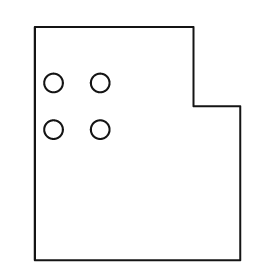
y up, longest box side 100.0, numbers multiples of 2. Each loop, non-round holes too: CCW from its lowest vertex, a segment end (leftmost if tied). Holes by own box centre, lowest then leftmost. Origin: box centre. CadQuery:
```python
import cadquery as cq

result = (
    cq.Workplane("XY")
    .moveTo(-44.0, -50.0)
    .lineTo(44.0, -50.0)
    .lineTo(44.0, 16.0)
    .lineTo(24.0, 16.0)
    .lineTo(24.0, 50.0)
    .lineTo(-44.0, 50.0)
    .close()
    .moveTo(-36.0, 6.0)
    .circle(4.0)
    .moveTo(-16.0, 6.0)
    .circle(4.0)
    .moveTo(-36.0, 26.0)
    .circle(4.0)
    .moveTo(-16.0, 26.0)
    .circle(4.0)
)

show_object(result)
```